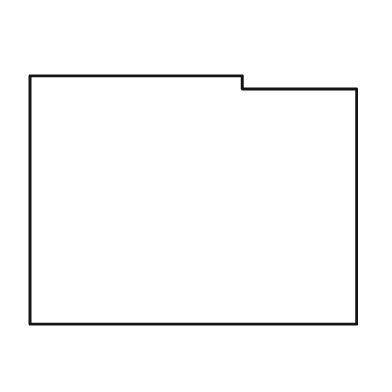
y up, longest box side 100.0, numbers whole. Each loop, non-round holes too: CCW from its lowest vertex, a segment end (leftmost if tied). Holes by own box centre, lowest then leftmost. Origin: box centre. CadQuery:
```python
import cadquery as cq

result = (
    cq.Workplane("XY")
    .moveTo(-50.0, -38.0)
    .lineTo(50.0, -38.0)
    .lineTo(50.0, 34.0)
    .lineTo(15.0, 34.0)
    .lineTo(15.0, 38.0)
    .lineTo(-50.0, 38.0)
    .close()
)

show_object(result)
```